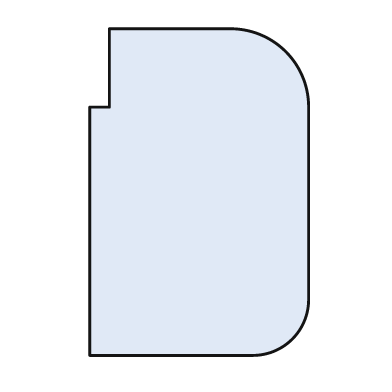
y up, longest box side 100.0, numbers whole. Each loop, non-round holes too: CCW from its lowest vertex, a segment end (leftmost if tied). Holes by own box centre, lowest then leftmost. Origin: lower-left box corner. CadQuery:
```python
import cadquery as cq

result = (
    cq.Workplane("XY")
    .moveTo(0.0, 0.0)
    .lineTo(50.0, 0.0)
    .threePointArc((62.0, 5.0), (67.0, 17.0))
    .lineTo(67.0, 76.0)
    .threePointArc((60.0, 93.0), (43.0, 100.0))
    .lineTo(6.0, 100.0)
    .lineTo(6.0, 76.0)
    .lineTo(0.0, 76.0)
    .close()
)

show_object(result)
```